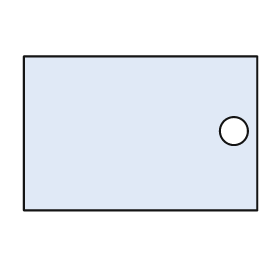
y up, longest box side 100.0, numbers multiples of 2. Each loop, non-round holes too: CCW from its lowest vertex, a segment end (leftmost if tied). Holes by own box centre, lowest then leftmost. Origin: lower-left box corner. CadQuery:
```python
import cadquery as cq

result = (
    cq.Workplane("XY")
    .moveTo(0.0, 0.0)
    .lineTo(100.0, 0.0)
    .lineTo(100.0, 66.0)
    .lineTo(0.0, 66.0)
    .close()
    .moveTo(90.0, 34.0)
    .circle(6.0)
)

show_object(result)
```